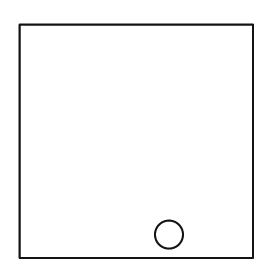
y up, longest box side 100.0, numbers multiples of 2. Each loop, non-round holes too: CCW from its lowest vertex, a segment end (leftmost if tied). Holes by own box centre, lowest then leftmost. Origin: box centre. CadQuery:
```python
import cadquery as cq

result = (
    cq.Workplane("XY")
    .moveTo(-50.0, -50.0)
    .lineTo(50.0, -50.0)
    .lineTo(50.0, 50.0)
    .lineTo(-50.0, 50.0)
    .close()
    .moveTo(14.0, -40.0)
    .circle(6.0)
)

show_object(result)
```